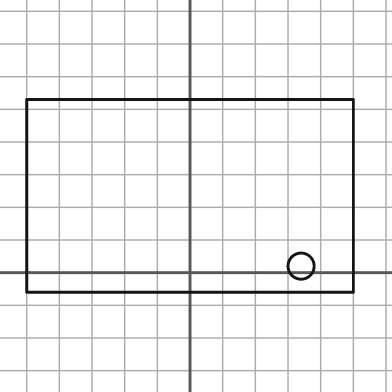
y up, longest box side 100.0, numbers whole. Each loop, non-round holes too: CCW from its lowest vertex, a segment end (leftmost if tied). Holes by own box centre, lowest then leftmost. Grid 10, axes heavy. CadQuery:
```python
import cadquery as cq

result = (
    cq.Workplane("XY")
    .moveTo(-50.0, -6.0)
    .lineTo(50.0, -6.0)
    .lineTo(50.0, 53.0)
    .lineTo(-50.0, 53.0)
    .close()
    .moveTo(34.0, 2.0)
    .circle(4.0)
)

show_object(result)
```